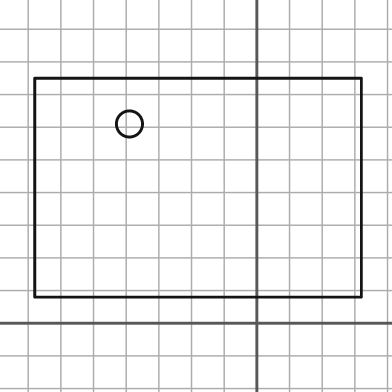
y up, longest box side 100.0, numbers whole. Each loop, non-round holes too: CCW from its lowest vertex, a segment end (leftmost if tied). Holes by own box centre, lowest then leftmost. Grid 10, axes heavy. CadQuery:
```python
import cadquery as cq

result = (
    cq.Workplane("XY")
    .moveTo(-68.0, 8.0)
    .lineTo(32.0, 8.0)
    .lineTo(32.0, 75.0)
    .lineTo(-68.0, 75.0)
    .close()
    .moveTo(-39.0, 61.0)
    .circle(4.0)
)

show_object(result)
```